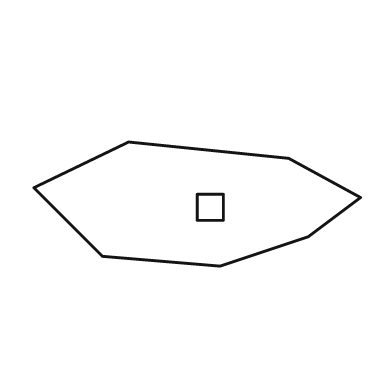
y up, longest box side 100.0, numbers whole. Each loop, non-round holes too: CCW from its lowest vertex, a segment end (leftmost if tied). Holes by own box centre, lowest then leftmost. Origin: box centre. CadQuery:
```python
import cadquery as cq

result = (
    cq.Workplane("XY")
    .moveTo(7.0, -19.0)
    .lineTo(34.0, -10.0)
    .lineTo(50.0, 2.0)
    .lineTo(28.0, 14.0)
    .lineTo(-21.0, 19.0)
    .lineTo(-50.0, 5.0)
    .lineTo(-29.0, -16.0)
    .close()
    .moveTo(0.0, -5.0)
    .lineTo(8.0, -5.0)
    .lineTo(8.0, 3.0)
    .lineTo(0.0, 3.0)
    .close()
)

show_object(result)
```